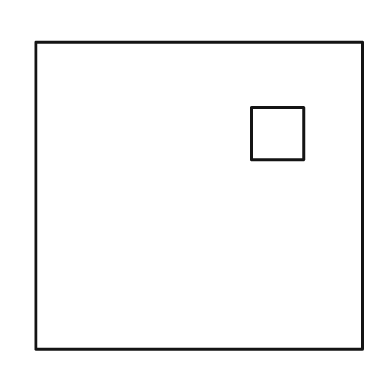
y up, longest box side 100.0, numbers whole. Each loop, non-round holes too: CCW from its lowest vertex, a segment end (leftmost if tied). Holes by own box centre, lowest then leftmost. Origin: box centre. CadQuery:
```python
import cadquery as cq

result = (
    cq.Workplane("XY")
    .moveTo(-50.0, -47.0)
    .lineTo(50.0, -47.0)
    .lineTo(50.0, 47.0)
    .lineTo(-50.0, 47.0)
    .close()
    .moveTo(16.0, 11.0)
    .lineTo(32.0, 11.0)
    .lineTo(32.0, 27.0)
    .lineTo(16.0, 27.0)
    .close()
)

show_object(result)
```